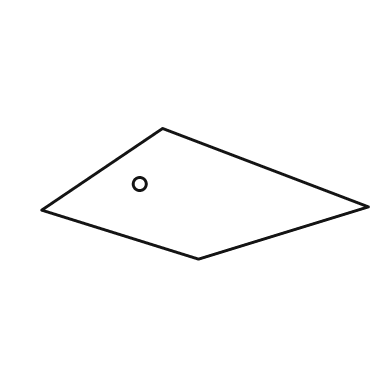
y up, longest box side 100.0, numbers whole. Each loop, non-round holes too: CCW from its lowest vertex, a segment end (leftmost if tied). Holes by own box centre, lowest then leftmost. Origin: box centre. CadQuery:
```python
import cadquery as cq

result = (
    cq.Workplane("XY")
    .moveTo(-2.0, -20.0)
    .lineTo(50.0, -4.0)
    .lineTo(-13.0, 20.0)
    .lineTo(-50.0, -5.0)
    .close()
    .moveTo(-20.0, 3.0)
    .circle(2.0)
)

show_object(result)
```